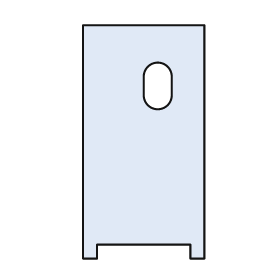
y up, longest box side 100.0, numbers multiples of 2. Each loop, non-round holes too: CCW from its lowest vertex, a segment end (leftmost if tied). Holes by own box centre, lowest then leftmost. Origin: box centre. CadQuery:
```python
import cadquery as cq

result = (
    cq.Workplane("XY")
    .moveTo(-26.0, -50.0)
    .lineTo(-20.0, -50.0)
    .lineTo(-20.0, -44.0)
    .lineTo(20.0, -44.0)
    .lineTo(20.0, -50.0)
    .lineTo(26.0, -50.0)
    .lineTo(26.0, 50.0)
    .lineTo(-26.0, 50.0)
    .close()
    .moveTo(0.0, 20.0)
    .threePointArc((6.0, 14.0), (12.0, 20.0))
    .lineTo(12.0, 28.0)
    .threePointArc((6.0, 34.0), (0.0, 28.0))
    .close()
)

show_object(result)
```